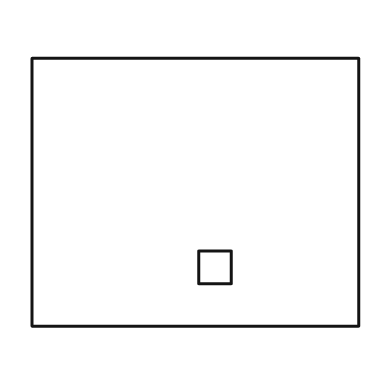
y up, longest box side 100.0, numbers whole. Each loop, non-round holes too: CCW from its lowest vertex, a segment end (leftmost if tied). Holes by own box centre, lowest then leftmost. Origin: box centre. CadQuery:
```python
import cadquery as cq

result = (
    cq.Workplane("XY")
    .moveTo(-50.0, -41.0)
    .lineTo(50.0, -41.0)
    .lineTo(50.0, 41.0)
    .lineTo(-50.0, 41.0)
    .close()
    .moveTo(1.0, -28.0)
    .lineTo(11.0, -28.0)
    .lineTo(11.0, -18.0)
    .lineTo(1.0, -18.0)
    .close()
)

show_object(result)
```